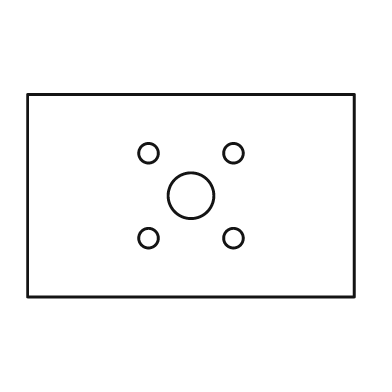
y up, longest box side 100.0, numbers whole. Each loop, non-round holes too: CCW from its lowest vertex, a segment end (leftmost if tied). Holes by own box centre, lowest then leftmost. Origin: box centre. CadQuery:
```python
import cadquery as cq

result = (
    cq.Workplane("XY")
    .moveTo(-50.0, -31.0)
    .lineTo(50.0, -31.0)
    .lineTo(50.0, 31.0)
    .lineTo(-50.0, 31.0)
    .close()
    .moveTo(-13.0, -13.0)
    .circle(3.0)
    .moveTo(13.0, -13.0)
    .circle(3.0)
    .moveTo(0.0, 0.0)
    .circle(7.0)
    .moveTo(-13.0, 13.0)
    .circle(3.0)
    .moveTo(13.0, 13.0)
    .circle(3.0)
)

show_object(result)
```